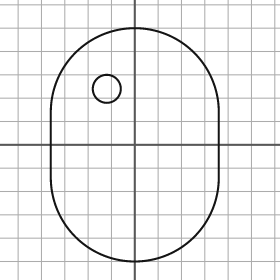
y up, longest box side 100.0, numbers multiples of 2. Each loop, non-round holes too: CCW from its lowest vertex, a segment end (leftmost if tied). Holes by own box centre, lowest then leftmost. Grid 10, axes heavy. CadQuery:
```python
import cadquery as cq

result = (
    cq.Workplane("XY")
    .moveTo(-36.0, -14.0)
    .threePointArc((0.0, -50.0), (36.0, -14.0))
    .lineTo(36.0, 14.0)
    .threePointArc((0.0, 50.0), (-36.0, 14.0))
    .close()
    .moveTo(-12.0, 24.0)
    .circle(6.0)
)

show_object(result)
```